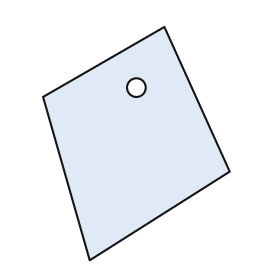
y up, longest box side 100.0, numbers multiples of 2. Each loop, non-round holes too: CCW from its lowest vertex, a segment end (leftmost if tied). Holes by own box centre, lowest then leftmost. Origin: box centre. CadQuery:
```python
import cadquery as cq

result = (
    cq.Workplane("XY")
    .moveTo(-20.0, -50.0)
    .lineTo(40.0, -12.0)
    .lineTo(12.0, 50.0)
    .lineTo(-40.0, 20.0)
    .close()
    .moveTo(0.0, 24.0)
    .circle(4.0)
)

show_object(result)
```